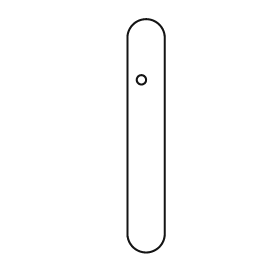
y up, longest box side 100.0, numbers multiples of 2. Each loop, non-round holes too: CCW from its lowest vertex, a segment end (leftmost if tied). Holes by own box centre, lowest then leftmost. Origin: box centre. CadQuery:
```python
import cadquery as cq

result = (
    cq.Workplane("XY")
    .moveTo(-8.0, -42.0)
    .threePointArc((0.0, -50.0), (8.0, -42.0))
    .lineTo(8.0, 42.0)
    .threePointArc((0.0, 50.0), (-8.0, 42.0))
    .close()
    .moveTo(-2.0, 24.0)
    .circle(2.0)
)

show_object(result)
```